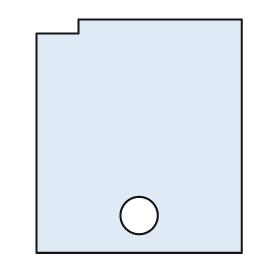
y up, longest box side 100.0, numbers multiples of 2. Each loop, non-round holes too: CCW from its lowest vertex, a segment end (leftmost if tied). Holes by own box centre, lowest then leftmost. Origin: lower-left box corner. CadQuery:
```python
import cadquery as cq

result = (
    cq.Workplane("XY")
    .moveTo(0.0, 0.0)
    .lineTo(88.0, 0.0)
    .lineTo(88.0, 100.0)
    .lineTo(18.0, 100.0)
    .lineTo(18.0, 94.0)
    .lineTo(0.0, 94.0)
    .close()
    .moveTo(44.0, 16.0)
    .circle(8.0)
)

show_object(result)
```